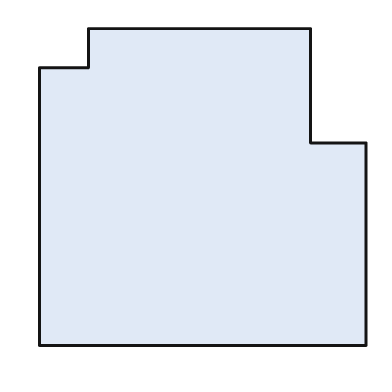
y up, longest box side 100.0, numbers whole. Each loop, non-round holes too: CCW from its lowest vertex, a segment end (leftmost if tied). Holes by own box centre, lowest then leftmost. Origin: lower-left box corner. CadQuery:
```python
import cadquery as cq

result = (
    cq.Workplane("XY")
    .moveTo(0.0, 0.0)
    .lineTo(100.0, 0.0)
    .lineTo(100.0, 62.0)
    .lineTo(83.0, 62.0)
    .lineTo(83.0, 97.0)
    .lineTo(15.0, 97.0)
    .lineTo(15.0, 85.0)
    .lineTo(0.0, 85.0)
    .close()
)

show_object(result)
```